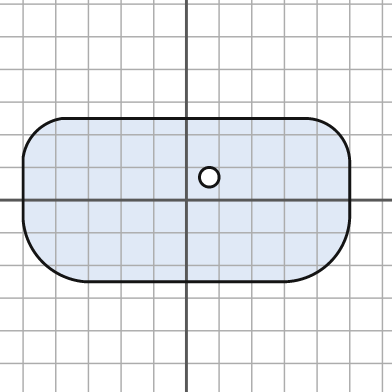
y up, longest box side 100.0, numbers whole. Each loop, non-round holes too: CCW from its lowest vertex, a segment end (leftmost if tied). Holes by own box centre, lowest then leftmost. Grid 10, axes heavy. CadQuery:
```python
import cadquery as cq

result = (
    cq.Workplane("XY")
    .moveTo(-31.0, -25.0)
    .lineTo(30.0, -25.0)
    .threePointArc((44.0, -19.0), (50.0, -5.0))
    .lineTo(50.0, 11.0)
    .threePointArc((46.0, 21.0), (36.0, 25.0))
    .lineTo(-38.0, 25.0)
    .threePointArc((-46.0, 21.0), (-50.0, 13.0))
    .lineTo(-50.0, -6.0)
    .threePointArc((-44.0, -19.0), (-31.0, -25.0))
    .close()
    .moveTo(7.0, 7.0)
    .circle(3.0)
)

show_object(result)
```